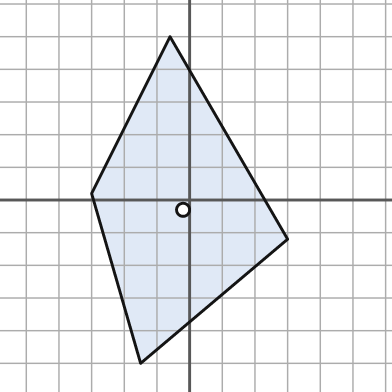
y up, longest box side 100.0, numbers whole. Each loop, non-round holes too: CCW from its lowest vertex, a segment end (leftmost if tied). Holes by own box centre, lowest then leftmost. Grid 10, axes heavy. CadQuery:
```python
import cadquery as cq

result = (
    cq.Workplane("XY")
    .moveTo(-15.0, -50.0)
    .lineTo(30.0, -12.0)
    .lineTo(-6.0, 50.0)
    .lineTo(-30.0, 2.0)
    .close()
    .moveTo(-2.0, -3.0)
    .circle(2.0)
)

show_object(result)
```